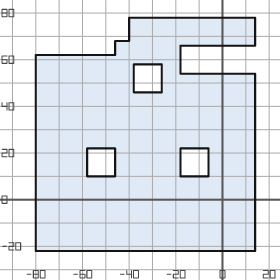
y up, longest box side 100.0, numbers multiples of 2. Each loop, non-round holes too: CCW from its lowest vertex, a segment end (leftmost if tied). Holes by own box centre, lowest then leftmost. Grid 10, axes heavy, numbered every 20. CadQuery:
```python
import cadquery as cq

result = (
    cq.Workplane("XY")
    .moveTo(-80.0, -22.0)
    .lineTo(14.0, -22.0)
    .lineTo(14.0, 54.0)
    .lineTo(-18.0, 54.0)
    .lineTo(-18.0, 66.0)
    .lineTo(14.0, 66.0)
    .lineTo(14.0, 78.0)
    .lineTo(-40.0, 78.0)
    .lineTo(-40.0, 68.0)
    .lineTo(-46.0, 68.0)
    .lineTo(-46.0, 62.0)
    .lineTo(-80.0, 62.0)
    .close()
    .moveTo(-58.0, 10.0)
    .lineTo(-46.0, 10.0)
    .lineTo(-46.0, 22.0)
    .lineTo(-58.0, 22.0)
    .close()
    .moveTo(-18.0, 10.0)
    .lineTo(-6.0, 10.0)
    .lineTo(-6.0, 22.0)
    .lineTo(-18.0, 22.0)
    .close()
    .moveTo(-38.0, 46.0)
    .lineTo(-26.0, 46.0)
    .lineTo(-26.0, 58.0)
    .lineTo(-38.0, 58.0)
    .close()
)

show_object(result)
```